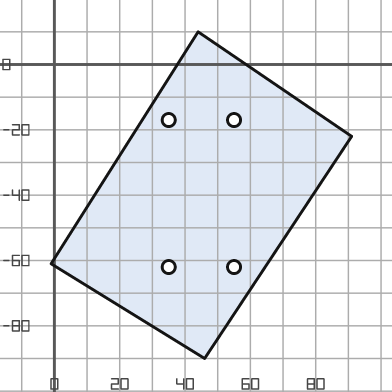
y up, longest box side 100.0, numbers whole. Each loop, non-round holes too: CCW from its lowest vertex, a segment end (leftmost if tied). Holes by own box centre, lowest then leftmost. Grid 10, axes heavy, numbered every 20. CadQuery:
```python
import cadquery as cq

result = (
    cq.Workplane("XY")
    .moveTo(46.0, -90.0)
    .lineTo(91.0, -22.0)
    .lineTo(44.0, 10.0)
    .lineTo(-1.0, -61.0)
    .close()
    .moveTo(35.0, -62.0)
    .circle(2.0)
    .moveTo(55.0, -62.0)
    .circle(2.0)
    .moveTo(35.0, -17.0)
    .circle(2.0)
    .moveTo(55.0, -17.0)
    .circle(2.0)
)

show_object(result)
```